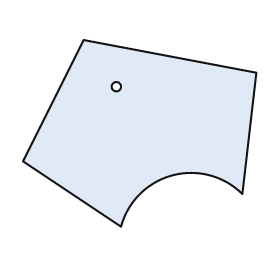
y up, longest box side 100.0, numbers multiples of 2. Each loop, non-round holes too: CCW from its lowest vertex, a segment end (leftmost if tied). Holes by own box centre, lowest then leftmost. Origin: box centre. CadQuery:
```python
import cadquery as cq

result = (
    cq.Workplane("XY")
    .moveTo(-8.0, -40.0)
    .threePointArc((14.0, -18.0), (44.0, -26.0))
    .lineTo(50.0, 26.0)
    .lineTo(-24.0, 40.0)
    .lineTo(-50.0, -12.0)
    .close()
    .moveTo(-10.0, 20.0)
    .circle(2.0)
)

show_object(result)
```